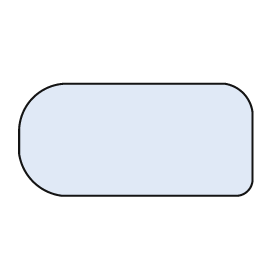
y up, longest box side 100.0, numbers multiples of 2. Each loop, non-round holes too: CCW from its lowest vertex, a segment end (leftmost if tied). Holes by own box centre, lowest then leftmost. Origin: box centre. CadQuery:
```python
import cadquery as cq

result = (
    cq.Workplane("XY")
    .moveTo(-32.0, -24.0)
    .lineTo(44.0, -24.0)
    .threePointArc((48.0, -22.0), (50.0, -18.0))
    .lineTo(50.0, 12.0)
    .threePointArc((46.0, 20.0), (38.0, 24.0))
    .lineTo(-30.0, 24.0)
    .threePointArc((-44.0, 18.0), (-50.0, 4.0))
    .lineTo(-50.0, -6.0)
    .threePointArc((-44.0, -18.0), (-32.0, -24.0))
    .close()
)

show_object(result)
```